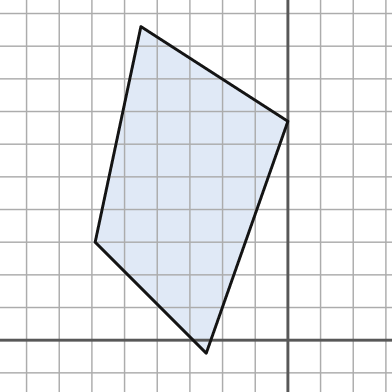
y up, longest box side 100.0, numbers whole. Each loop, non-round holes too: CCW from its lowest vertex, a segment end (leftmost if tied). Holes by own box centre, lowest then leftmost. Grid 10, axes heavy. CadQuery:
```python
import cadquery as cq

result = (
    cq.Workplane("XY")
    .moveTo(-25.0, -4.0)
    .lineTo(0.0, 67.0)
    .lineTo(-45.0, 96.0)
    .lineTo(-59.0, 30.0)
    .close()
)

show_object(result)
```